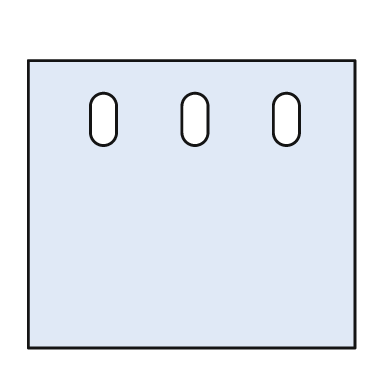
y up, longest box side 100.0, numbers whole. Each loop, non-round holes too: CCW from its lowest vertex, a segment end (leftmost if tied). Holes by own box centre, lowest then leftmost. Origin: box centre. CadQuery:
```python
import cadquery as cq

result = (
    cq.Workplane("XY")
    .moveTo(-50.0, -44.0)
    .lineTo(50.0, -44.0)
    .lineTo(50.0, 44.0)
    .lineTo(-50.0, 44.0)
    .close()
    .moveTo(-31.0, 22.0)
    .threePointArc((-27.0, 18.0), (-23.0, 22.0))
    .lineTo(-23.0, 30.0)
    .threePointArc((-27.0, 34.0), (-31.0, 30.0))
    .close()
    .moveTo(-3.0, 22.0)
    .threePointArc((1.0, 18.0), (5.0, 22.0))
    .lineTo(5.0, 30.0)
    .threePointArc((1.0, 34.0), (-3.0, 30.0))
    .close()
    .moveTo(25.0, 22.0)
    .threePointArc((29.0, 18.0), (33.0, 22.0))
    .lineTo(33.0, 30.0)
    .threePointArc((29.0, 34.0), (25.0, 30.0))
    .close()
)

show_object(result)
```